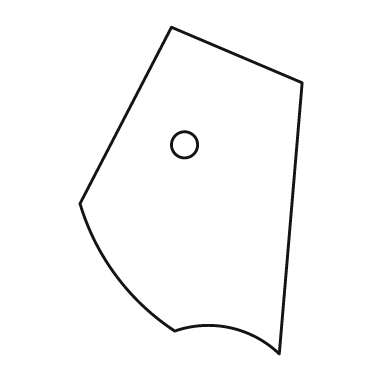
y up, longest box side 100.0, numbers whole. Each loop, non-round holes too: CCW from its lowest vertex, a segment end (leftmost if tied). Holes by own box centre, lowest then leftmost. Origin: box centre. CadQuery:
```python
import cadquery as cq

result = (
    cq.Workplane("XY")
    .moveTo(27.0, -50.0)
    .lineTo(34.0, 33.0)
    .lineTo(-6.0, 50.0)
    .lineTo(-34.0, -4.0)
    .threePointArc((-23.0, -26.0), (-5.0, -43.0))
    .threePointArc((12.0, -42.0), (27.0, -50.0))
    .close()
    .moveTo(-2.0, 14.0)
    .circle(4.0)
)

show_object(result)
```